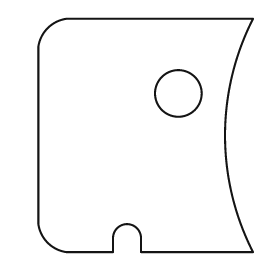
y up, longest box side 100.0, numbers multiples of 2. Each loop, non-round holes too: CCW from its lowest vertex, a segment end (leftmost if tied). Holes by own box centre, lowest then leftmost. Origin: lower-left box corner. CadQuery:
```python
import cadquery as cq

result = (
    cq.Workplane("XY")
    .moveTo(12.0, 0.0)
    .lineTo(32.0, 0.0)
    .lineTo(32.0, 6.0)
    .threePointArc((38.0, 12.0), (44.0, 6.0))
    .lineTo(44.0, 0.0)
    .lineTo(92.0, 0.0)
    .threePointArc((80.0, 50.0), (92.0, 100.0))
    .lineTo(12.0, 100.0)
    .threePointArc((4.0, 96.0), (0.0, 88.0))
    .lineTo(0.0, 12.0)
    .threePointArc((4.0, 4.0), (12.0, 0.0))
    .close()
    .moveTo(60.0, 68.0)
    .circle(10.0)
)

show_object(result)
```